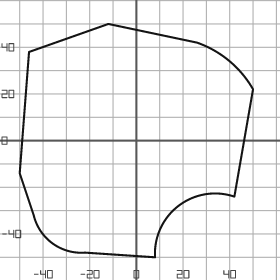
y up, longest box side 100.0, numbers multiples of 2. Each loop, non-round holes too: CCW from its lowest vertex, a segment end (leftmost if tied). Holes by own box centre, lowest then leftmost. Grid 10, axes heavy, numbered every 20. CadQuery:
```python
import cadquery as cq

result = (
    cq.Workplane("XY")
    .moveTo(8.0, -50.0)
    .threePointArc((18.0, -28.0), (42.0, -24.0))
    .lineTo(50.0, 22.0)
    .threePointArc((40.0, 34.0), (26.0, 42.0))
    .lineTo(-12.0, 50.0)
    .lineTo(-46.0, 38.0)
    .lineTo(-50.0, -14.0)
    .lineTo(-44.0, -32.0)
    .threePointArc((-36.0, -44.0), (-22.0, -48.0))
    .close()
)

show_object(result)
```